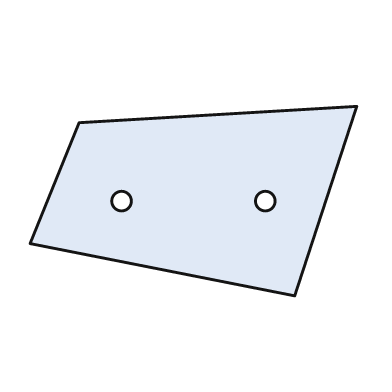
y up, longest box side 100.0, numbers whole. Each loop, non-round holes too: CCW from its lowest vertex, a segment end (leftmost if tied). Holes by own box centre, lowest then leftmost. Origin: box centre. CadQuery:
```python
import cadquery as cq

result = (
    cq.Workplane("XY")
    .moveTo(31.0, -29.0)
    .lineTo(50.0, 29.0)
    .lineTo(-35.0, 24.0)
    .lineTo(-50.0, -13.0)
    .close()
    .moveTo(-22.0, 0.0)
    .circle(3.0)
    .moveTo(22.0, 0.0)
    .circle(3.0)
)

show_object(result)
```